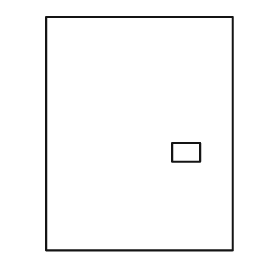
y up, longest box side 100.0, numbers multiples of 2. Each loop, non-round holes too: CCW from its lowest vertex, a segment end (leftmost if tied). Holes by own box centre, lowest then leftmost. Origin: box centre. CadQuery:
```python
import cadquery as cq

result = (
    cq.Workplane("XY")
    .moveTo(-40.0, -50.0)
    .lineTo(40.0, -50.0)
    .lineTo(40.0, 50.0)
    .lineTo(-40.0, 50.0)
    .close()
    .moveTo(14.0, -12.0)
    .lineTo(26.0, -12.0)
    .lineTo(26.0, -4.0)
    .lineTo(14.0, -4.0)
    .close()
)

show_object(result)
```